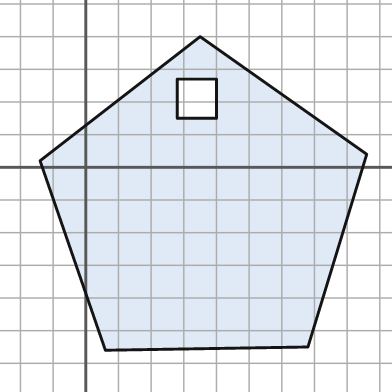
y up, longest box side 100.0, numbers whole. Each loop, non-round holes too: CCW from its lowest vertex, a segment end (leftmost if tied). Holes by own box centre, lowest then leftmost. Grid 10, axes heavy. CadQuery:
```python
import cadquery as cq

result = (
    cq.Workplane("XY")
    .moveTo(6.0, -56.0)
    .lineTo(68.0, -55.0)
    .lineTo(86.0, 4.0)
    .lineTo(35.0, 40.0)
    .lineTo(-14.0, 2.0)
    .close()
    .moveTo(28.0, 15.0)
    .lineTo(40.0, 15.0)
    .lineTo(40.0, 27.0)
    .lineTo(28.0, 27.0)
    .close()
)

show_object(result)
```